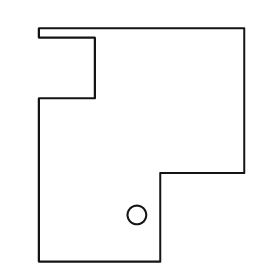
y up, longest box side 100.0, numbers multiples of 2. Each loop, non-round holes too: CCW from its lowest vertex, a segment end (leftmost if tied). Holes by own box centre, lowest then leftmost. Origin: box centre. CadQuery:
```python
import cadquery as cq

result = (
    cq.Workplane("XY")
    .moveTo(-44.0, -50.0)
    .lineTo(8.0, -50.0)
    .lineTo(8.0, -12.0)
    .lineTo(44.0, -12.0)
    .lineTo(44.0, 50.0)
    .lineTo(-44.0, 50.0)
    .lineTo(-44.0, 46.0)
    .lineTo(-20.0, 46.0)
    .lineTo(-20.0, 20.0)
    .lineTo(-44.0, 20.0)
    .close()
    .moveTo(-2.0, -30.0)
    .circle(4.0)
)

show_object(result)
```